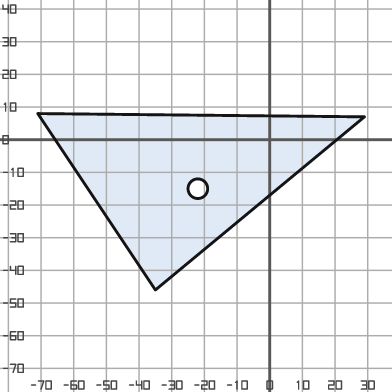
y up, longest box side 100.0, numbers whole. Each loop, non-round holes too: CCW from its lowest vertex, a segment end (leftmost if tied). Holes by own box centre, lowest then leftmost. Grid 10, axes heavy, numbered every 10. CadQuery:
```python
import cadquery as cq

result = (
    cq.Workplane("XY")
    .moveTo(-35.0, -46.0)
    .lineTo(29.0, 7.0)
    .lineTo(-71.0, 8.0)
    .close()
    .moveTo(-22.0, -15.0)
    .circle(3.0)
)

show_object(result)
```